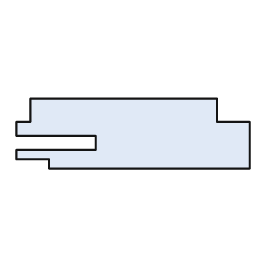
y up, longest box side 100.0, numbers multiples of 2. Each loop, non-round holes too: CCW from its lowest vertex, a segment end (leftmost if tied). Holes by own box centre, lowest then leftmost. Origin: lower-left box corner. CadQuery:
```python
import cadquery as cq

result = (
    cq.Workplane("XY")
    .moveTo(14.0, 0.0)
    .lineTo(100.0, 0.0)
    .lineTo(100.0, 20.0)
    .lineTo(86.0, 20.0)
    .lineTo(86.0, 30.0)
    .lineTo(6.0, 30.0)
    .lineTo(6.0, 20.0)
    .lineTo(0.0, 20.0)
    .lineTo(0.0, 14.0)
    .lineTo(34.0, 14.0)
    .lineTo(34.0, 8.0)
    .lineTo(0.0, 8.0)
    .lineTo(0.0, 4.0)
    .lineTo(14.0, 4.0)
    .close()
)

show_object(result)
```